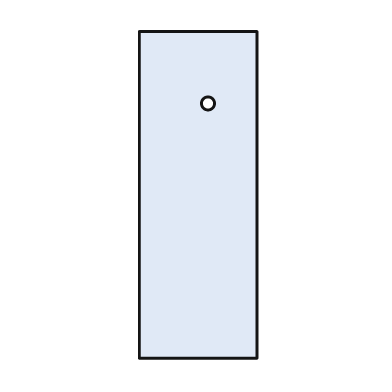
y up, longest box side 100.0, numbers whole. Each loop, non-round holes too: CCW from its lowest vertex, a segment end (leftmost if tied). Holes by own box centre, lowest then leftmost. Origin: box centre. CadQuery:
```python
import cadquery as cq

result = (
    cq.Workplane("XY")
    .moveTo(-18.0, -50.0)
    .lineTo(18.0, -50.0)
    .lineTo(18.0, 50.0)
    .lineTo(-18.0, 50.0)
    .close()
    .moveTo(3.0, 28.0)
    .circle(2.0)
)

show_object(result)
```